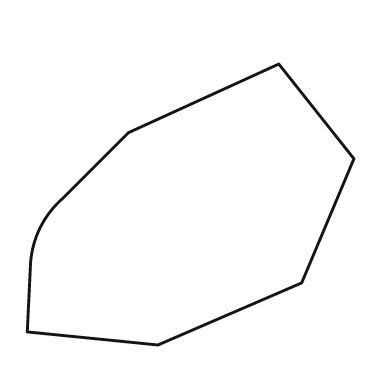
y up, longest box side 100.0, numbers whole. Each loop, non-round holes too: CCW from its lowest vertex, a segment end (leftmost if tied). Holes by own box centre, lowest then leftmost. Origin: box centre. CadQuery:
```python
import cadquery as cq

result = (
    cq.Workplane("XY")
    .moveTo(-10.0, -43.0)
    .lineTo(34.0, -24.0)
    .lineTo(50.0, 14.0)
    .lineTo(27.0, 43.0)
    .lineTo(-19.0, 22.0)
    .lineTo(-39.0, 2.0)
    .threePointArc((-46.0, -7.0), (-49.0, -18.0))
    .lineTo(-50.0, -39.0)
    .close()
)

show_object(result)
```